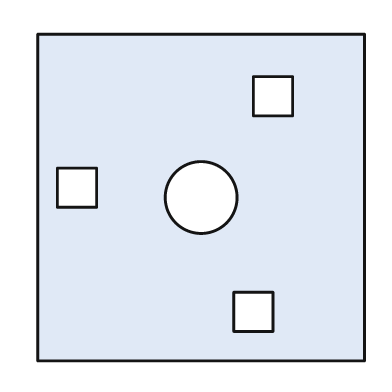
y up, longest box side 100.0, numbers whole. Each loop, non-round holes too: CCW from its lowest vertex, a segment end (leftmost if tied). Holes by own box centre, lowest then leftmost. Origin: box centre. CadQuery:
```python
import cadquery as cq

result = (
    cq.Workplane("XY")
    .moveTo(-50.0, -50.0)
    .lineTo(50.0, -50.0)
    .lineTo(50.0, 50.0)
    .lineTo(-50.0, 50.0)
    .close()
    .moveTo(10.0, -41.0)
    .lineTo(22.0, -41.0)
    .lineTo(22.0, -29.0)
    .lineTo(10.0, -29.0)
    .close()
    .moveTo(0.0, 0.0)
    .circle(11.0)
    .moveTo(-44.0, -3.0)
    .lineTo(-32.0, -3.0)
    .lineTo(-32.0, 9.0)
    .lineTo(-44.0, 9.0)
    .close()
    .moveTo(16.0, 25.0)
    .lineTo(28.0, 25.0)
    .lineTo(28.0, 37.0)
    .lineTo(16.0, 37.0)
    .close()
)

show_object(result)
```